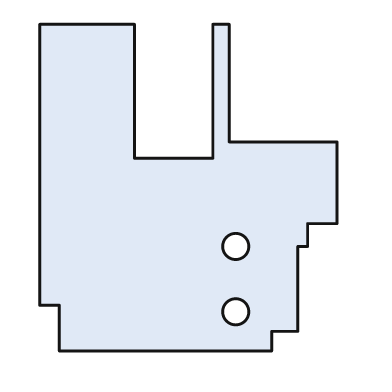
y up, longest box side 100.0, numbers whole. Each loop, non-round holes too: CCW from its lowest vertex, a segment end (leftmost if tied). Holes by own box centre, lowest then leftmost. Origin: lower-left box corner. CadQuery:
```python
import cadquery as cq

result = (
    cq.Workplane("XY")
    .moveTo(6.0, 0.0)
    .lineTo(71.0, 0.0)
    .lineTo(71.0, 6.0)
    .lineTo(79.0, 6.0)
    .lineTo(79.0, 32.0)
    .lineTo(82.0, 32.0)
    .lineTo(82.0, 39.0)
    .lineTo(91.0, 39.0)
    .lineTo(91.0, 64.0)
    .lineTo(58.0, 64.0)
    .lineTo(58.0, 100.0)
    .lineTo(53.0, 100.0)
    .lineTo(53.0, 59.0)
    .lineTo(29.0, 59.0)
    .lineTo(29.0, 100.0)
    .lineTo(0.0, 100.0)
    .lineTo(0.0, 14.0)
    .lineTo(6.0, 14.0)
    .close()
    .moveTo(60.0, 12.0)
    .circle(4.0)
    .moveTo(60.0, 32.0)
    .circle(4.0)
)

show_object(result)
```